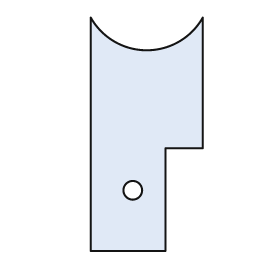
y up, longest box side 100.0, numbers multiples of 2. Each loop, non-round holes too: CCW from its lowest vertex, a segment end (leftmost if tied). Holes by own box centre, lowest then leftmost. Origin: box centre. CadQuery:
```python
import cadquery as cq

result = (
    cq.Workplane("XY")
    .moveTo(-24.0, -50.0)
    .lineTo(8.0, -50.0)
    .lineTo(8.0, -6.0)
    .lineTo(24.0, -6.0)
    .lineTo(24.0, 50.0)
    .threePointArc((0.0, 36.0), (-24.0, 50.0))
    .close()
    .moveTo(-6.0, -24.0)
    .circle(4.0)
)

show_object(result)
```